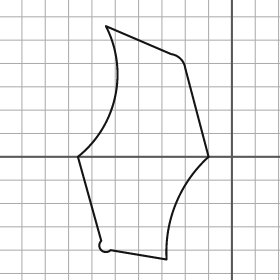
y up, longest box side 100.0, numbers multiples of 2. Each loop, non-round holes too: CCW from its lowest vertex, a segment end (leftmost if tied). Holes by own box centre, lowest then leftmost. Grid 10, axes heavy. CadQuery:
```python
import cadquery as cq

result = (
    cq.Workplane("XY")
    .moveTo(-28.0, -44.0)
    .threePointArc((-24.0, -20.0), (-10.0, 0.0))
    .lineTo(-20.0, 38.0)
    .threePointArc((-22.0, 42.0), (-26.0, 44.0))
    .lineTo(-54.0, 56.0)
    .threePointArc((-50.0, 26.0), (-66.0, 0.0))
    .lineTo(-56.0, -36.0)
    .threePointArc((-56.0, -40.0), (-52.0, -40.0))
    .close()
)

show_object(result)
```